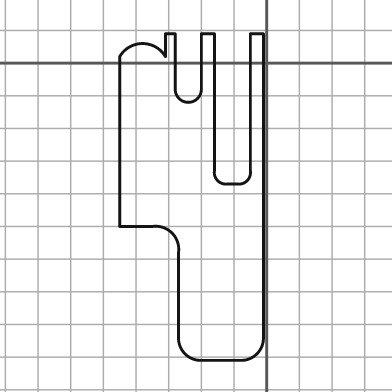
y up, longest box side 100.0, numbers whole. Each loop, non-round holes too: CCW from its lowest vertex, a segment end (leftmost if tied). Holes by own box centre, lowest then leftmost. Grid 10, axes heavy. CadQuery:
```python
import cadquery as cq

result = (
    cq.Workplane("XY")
    .moveTo(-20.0, -91.0)
    .lineTo(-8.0, -91.0)
    .threePointArc((-3.0, -89.0), (-1.0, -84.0))
    .lineTo(-1.0, 9.0)
    .lineTo(-5.0, 9.0)
    .lineTo(-5.0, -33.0)
    .threePointArc((-6.0, -36.0), (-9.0, -37.0))
    .lineTo(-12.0, -37.0)
    .threePointArc((-15.0, -36.0), (-16.0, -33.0))
    .lineTo(-16.0, 9.0)
    .lineTo(-20.0, 9.0)
    .lineTo(-20.0, -8.0)
    .threePointArc((-24.0, -12.0), (-28.0, -8.0))
    .lineTo(-28.0, 9.0)
    .lineTo(-31.0, 9.0)
    .lineTo(-31.0, 2.0)
    .threePointArc((-38.0, 6.0), (-45.0, 2.0))
    .lineTo(-45.0, -50.0)
    .lineTo(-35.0, -50.0)
    .threePointArc((-29.0, -52.0), (-27.0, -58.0))
    .lineTo(-27.0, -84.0)
    .threePointArc((-25.0, -89.0), (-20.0, -91.0))
    .close()
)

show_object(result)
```